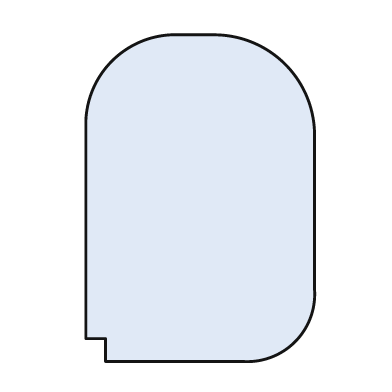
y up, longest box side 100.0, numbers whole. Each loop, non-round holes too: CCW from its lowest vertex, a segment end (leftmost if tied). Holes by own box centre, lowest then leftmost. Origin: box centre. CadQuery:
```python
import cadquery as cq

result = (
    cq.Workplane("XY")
    .moveTo(-29.0, -50.0)
    .lineTo(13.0, -50.0)
    .threePointArc((29.0, -44.0), (35.0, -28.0))
    .lineTo(35.0, 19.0)
    .threePointArc((26.0, 41.0), (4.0, 50.0))
    .lineTo(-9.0, 50.0)
    .threePointArc((-27.0, 42.0), (-35.0, 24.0))
    .lineTo(-35.0, -43.0)
    .lineTo(-29.0, -43.0)
    .close()
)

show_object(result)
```